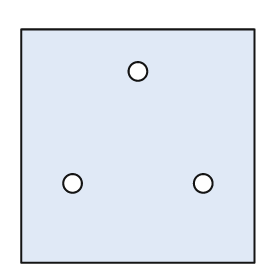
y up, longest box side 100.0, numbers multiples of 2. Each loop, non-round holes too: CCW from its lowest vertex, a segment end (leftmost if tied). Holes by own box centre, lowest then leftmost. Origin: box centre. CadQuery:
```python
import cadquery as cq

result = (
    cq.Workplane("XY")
    .moveTo(-50.0, -50.0)
    .lineTo(50.0, -50.0)
    .lineTo(50.0, 50.0)
    .lineTo(-50.0, 50.0)
    .close()
    .moveTo(-28.0, -16.0)
    .circle(4.0)
    .moveTo(28.0, -16.0)
    .circle(4.0)
    .moveTo(0.0, 32.0)
    .circle(4.0)
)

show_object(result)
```